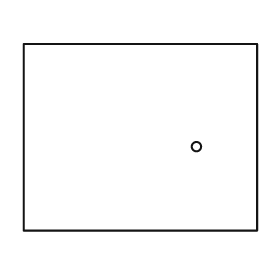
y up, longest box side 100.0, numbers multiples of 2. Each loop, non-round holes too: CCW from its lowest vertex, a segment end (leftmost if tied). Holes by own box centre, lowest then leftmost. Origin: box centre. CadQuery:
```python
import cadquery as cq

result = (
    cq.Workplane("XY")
    .moveTo(-50.0, -40.0)
    .lineTo(50.0, -40.0)
    .lineTo(50.0, 40.0)
    .lineTo(-50.0, 40.0)
    .close()
    .moveTo(24.0, -4.0)
    .circle(2.0)
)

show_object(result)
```